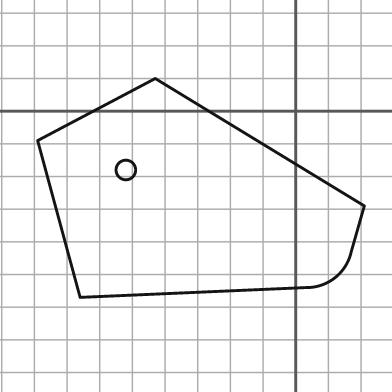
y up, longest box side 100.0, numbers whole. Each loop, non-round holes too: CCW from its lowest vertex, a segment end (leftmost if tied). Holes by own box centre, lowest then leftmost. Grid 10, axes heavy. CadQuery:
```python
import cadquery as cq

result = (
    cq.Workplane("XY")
    .moveTo(-66.0, -57.0)
    .lineTo(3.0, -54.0)
    .threePointArc((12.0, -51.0), (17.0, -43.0))
    .lineTo(21.0, -29.0)
    .lineTo(-43.0, 10.0)
    .lineTo(-79.0, -9.0)
    .close()
    .moveTo(-52.0, -18.0)
    .circle(3.0)
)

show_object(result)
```